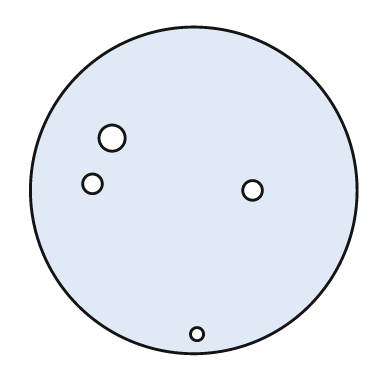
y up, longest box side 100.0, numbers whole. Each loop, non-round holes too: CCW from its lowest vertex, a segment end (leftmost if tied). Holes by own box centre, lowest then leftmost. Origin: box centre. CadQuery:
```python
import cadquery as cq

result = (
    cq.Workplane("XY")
    .moveTo(0.0, 0.0)
    .circle(50.0)
    .moveTo(1.0, -44.0)
    .circle(2.0)
    .moveTo(18.0, 0.0)
    .circle(3.0)
    .moveTo(-31.0, 2.0)
    .circle(3.0)
    .moveTo(-25.0, 16.0)
    .circle(4.0)
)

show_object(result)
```